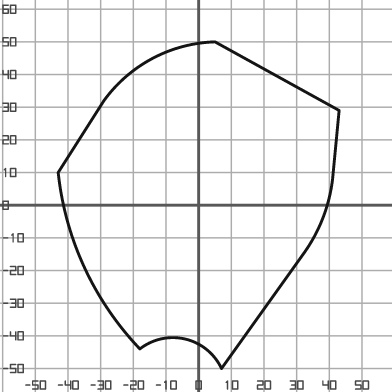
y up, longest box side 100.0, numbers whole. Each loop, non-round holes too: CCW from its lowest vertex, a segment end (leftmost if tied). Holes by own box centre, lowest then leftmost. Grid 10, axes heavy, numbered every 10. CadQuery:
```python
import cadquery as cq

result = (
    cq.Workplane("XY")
    .moveTo(7.0, -50.0)
    .lineTo(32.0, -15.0)
    .threePointArc((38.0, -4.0), (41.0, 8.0))
    .lineTo(43.0, 29.0)
    .lineTo(5.0, 50.0)
    .threePointArc((-14.0, 45.0), (-29.0, 32.0))
    .lineTo(-43.0, 10.0)
    .threePointArc((-35.0, -19.0), (-18.0, -44.0))
    .threePointArc((-4.0, -41.0), (7.0, -50.0))
    .close()
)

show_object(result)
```